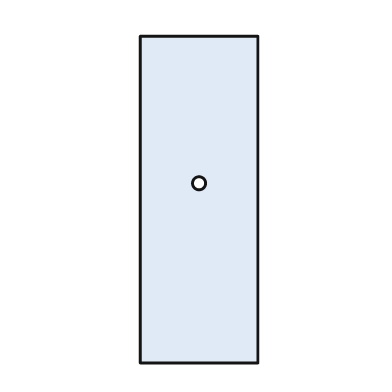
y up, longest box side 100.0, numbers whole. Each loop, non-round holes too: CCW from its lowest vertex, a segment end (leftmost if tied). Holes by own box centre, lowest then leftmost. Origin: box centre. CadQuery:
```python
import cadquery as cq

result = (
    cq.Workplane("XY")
    .moveTo(-18.0, -50.0)
    .lineTo(18.0, -50.0)
    .lineTo(18.0, 50.0)
    .lineTo(-18.0, 50.0)
    .close()
    .moveTo(0.0, 5.0)
    .circle(2.0)
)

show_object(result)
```